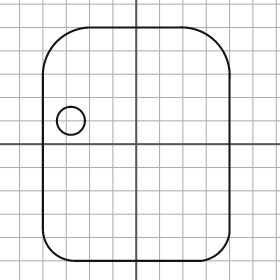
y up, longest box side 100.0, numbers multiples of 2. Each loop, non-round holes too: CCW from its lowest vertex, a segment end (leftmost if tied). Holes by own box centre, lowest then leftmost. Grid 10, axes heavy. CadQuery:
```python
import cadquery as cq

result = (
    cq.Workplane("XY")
    .moveTo(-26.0, -50.0)
    .lineTo(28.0, -50.0)
    .threePointArc((36.0, -46.0), (40.0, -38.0))
    .lineTo(40.0, 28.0)
    .threePointArc((34.0, 44.0), (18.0, 50.0))
    .lineTo(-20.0, 50.0)
    .threePointArc((-34.0, 44.0), (-40.0, 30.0))
    .lineTo(-40.0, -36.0)
    .threePointArc((-36.0, -46.0), (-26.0, -50.0))
    .close()
    .moveTo(-28.0, 10.0)
    .circle(6.0)
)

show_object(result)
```